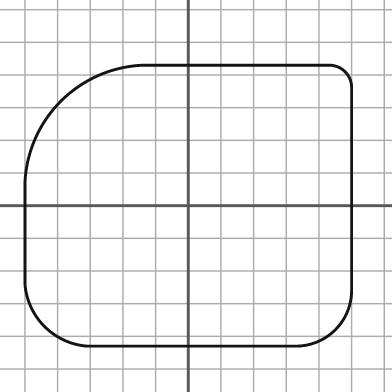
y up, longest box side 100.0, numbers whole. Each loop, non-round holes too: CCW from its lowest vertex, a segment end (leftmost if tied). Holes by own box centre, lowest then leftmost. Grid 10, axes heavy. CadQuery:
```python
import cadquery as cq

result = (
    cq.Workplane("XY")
    .moveTo(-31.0, -43.0)
    .lineTo(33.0, -43.0)
    .threePointArc((45.0, -38.0), (50.0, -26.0))
    .lineTo(50.0, 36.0)
    .threePointArc((48.0, 41.0), (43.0, 43.0))
    .lineTo(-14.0, 43.0)
    .threePointArc((-39.0, 32.0), (-50.0, 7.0))
    .lineTo(-50.0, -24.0)
    .threePointArc((-44.0, -37.0), (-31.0, -43.0))
    .close()
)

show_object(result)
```